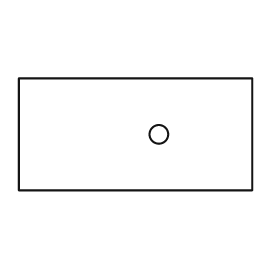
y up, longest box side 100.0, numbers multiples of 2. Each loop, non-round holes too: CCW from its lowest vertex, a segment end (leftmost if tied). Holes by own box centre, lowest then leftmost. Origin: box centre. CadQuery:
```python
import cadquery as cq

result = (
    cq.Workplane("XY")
    .moveTo(-50.0, -24.0)
    .lineTo(50.0, -24.0)
    .lineTo(50.0, 24.0)
    .lineTo(-50.0, 24.0)
    .close()
    .moveTo(10.0, 0.0)
    .circle(4.0)
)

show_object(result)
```